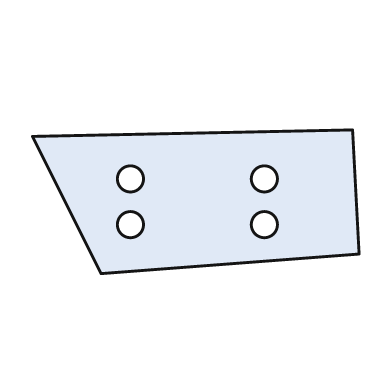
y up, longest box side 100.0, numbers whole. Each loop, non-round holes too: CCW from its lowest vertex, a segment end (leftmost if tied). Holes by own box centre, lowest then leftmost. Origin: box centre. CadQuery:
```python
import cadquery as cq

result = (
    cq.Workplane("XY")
    .moveTo(-29.0, -22.0)
    .lineTo(50.0, -16.0)
    .lineTo(48.0, 22.0)
    .lineTo(-50.0, 20.0)
    .close()
    .moveTo(-20.0, -7.0)
    .circle(4.0)
    .moveTo(21.0, -7.0)
    .circle(4.0)
    .moveTo(-20.0, 7.0)
    .circle(4.0)
    .moveTo(21.0, 7.0)
    .circle(4.0)
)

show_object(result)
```